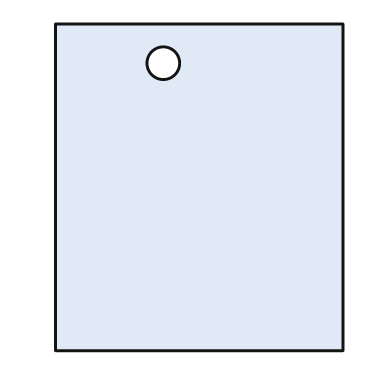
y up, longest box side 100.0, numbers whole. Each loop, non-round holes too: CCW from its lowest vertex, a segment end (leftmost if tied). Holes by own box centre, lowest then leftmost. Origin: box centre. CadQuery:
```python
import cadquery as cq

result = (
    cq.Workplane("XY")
    .moveTo(-44.0, -50.0)
    .lineTo(44.0, -50.0)
    .lineTo(44.0, 50.0)
    .lineTo(-44.0, 50.0)
    .close()
    .moveTo(-11.0, 38.0)
    .circle(5.0)
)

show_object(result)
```